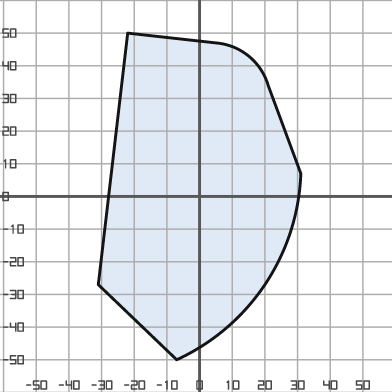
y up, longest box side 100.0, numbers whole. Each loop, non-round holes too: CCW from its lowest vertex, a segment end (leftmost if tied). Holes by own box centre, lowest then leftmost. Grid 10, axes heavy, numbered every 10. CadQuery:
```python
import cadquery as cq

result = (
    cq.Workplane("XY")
    .moveTo(-7.0, -50.0)
    .threePointArc((20.0, -27.0), (31.0, 7.0))
    .lineTo(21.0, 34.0)
    .threePointArc((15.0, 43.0), (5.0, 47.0))
    .lineTo(-22.0, 50.0)
    .lineTo(-31.0, -27.0)
    .close()
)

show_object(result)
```